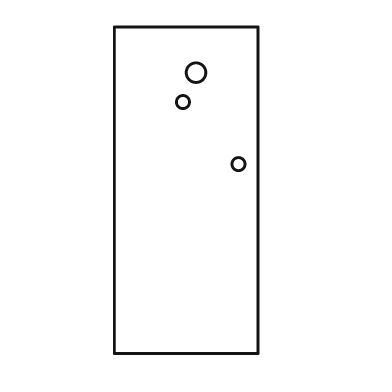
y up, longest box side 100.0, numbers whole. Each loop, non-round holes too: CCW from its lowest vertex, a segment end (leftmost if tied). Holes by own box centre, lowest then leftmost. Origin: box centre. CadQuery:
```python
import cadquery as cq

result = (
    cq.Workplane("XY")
    .moveTo(-22.0, -50.0)
    .lineTo(22.0, -50.0)
    .lineTo(22.0, 50.0)
    .lineTo(-22.0, 50.0)
    .close()
    .moveTo(16.0, 8.0)
    .circle(2.0)
    .moveTo(-1.0, 27.0)
    .circle(2.0)
    .moveTo(3.0, 36.0)
    .circle(3.0)
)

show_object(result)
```